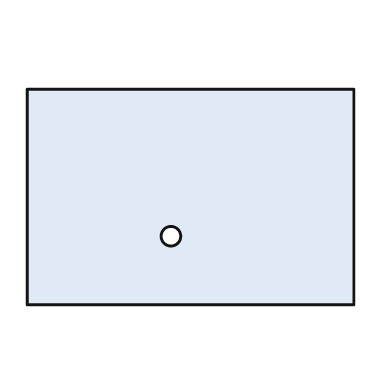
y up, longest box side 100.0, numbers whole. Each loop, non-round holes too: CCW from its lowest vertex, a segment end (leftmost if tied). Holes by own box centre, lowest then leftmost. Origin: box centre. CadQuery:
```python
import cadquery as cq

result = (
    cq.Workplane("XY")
    .moveTo(-50.0, -33.0)
    .lineTo(50.0, -33.0)
    .lineTo(50.0, 33.0)
    .lineTo(-50.0, 33.0)
    .close()
    .moveTo(-6.0, -12.0)
    .circle(3.0)
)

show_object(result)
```